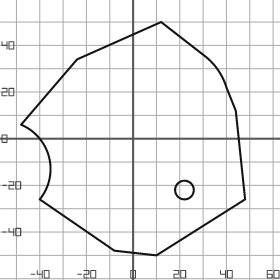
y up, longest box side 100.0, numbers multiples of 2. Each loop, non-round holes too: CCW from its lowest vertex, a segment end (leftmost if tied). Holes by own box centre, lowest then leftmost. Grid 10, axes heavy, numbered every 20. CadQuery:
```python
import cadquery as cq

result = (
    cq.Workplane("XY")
    .moveTo(10.0, -50.0)
    .lineTo(48.0, -26.0)
    .lineTo(44.0, 12.0)
    .lineTo(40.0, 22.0)
    .threePointArc((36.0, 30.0), (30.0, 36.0))
    .lineTo(12.0, 50.0)
    .lineTo(-24.0, 34.0)
    .lineTo(-48.0, 6.0)
    .threePointArc((-36.0, -8.0), (-40.0, -26.0))
    .lineTo(-8.0, -48.0)
    .close()
    .moveTo(22.0, -22.0)
    .circle(4.0)
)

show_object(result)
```